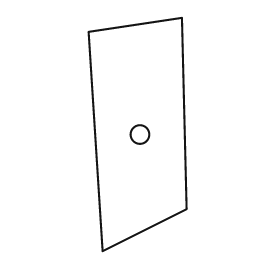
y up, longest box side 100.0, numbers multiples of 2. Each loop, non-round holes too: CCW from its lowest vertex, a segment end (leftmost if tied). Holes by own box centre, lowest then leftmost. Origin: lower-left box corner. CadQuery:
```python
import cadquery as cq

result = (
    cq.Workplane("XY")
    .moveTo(6.0, 0.0)
    .lineTo(42.0, 18.0)
    .lineTo(40.0, 100.0)
    .lineTo(0.0, 94.0)
    .close()
    .moveTo(22.0, 50.0)
    .circle(4.0)
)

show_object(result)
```